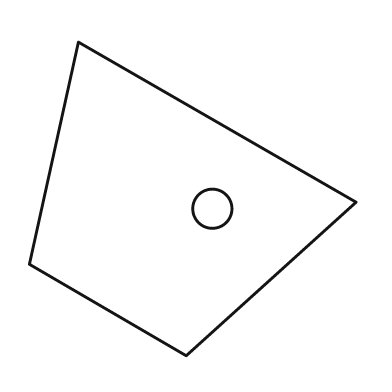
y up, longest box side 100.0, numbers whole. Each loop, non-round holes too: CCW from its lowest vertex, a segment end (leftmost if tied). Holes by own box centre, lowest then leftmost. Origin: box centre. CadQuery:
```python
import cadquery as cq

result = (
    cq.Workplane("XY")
    .moveTo(-2.0, -48.0)
    .lineTo(50.0, -1.0)
    .lineTo(-35.0, 48.0)
    .lineTo(-50.0, -20.0)
    .close()
    .moveTo(6.0, -3.0)
    .circle(6.0)
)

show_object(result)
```